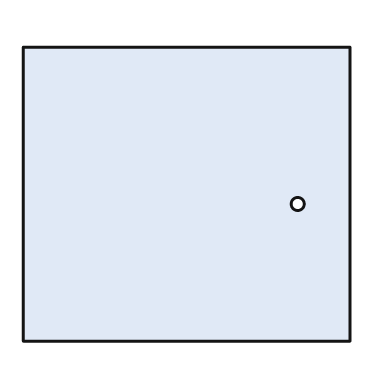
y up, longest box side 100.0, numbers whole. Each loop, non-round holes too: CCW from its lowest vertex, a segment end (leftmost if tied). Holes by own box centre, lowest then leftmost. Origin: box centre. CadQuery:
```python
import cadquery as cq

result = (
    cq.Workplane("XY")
    .moveTo(-50.0, -45.0)
    .lineTo(50.0, -45.0)
    .lineTo(50.0, 45.0)
    .lineTo(-50.0, 45.0)
    .close()
    .moveTo(34.0, -3.0)
    .circle(2.0)
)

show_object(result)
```